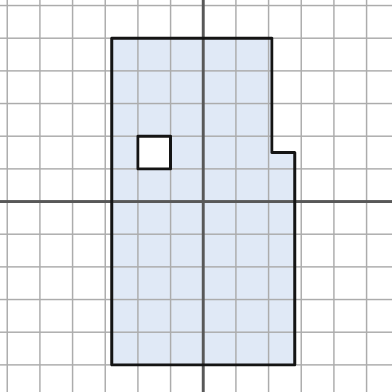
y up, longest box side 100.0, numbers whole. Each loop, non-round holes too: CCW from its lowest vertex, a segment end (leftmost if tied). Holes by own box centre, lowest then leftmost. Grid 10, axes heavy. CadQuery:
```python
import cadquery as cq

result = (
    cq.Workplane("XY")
    .moveTo(-28.0, -50.0)
    .lineTo(28.0, -50.0)
    .lineTo(28.0, 15.0)
    .lineTo(21.0, 15.0)
    .lineTo(21.0, 50.0)
    .lineTo(-28.0, 50.0)
    .close()
    .moveTo(-20.0, 10.0)
    .lineTo(-10.0, 10.0)
    .lineTo(-10.0, 20.0)
    .lineTo(-20.0, 20.0)
    .close()
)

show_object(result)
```